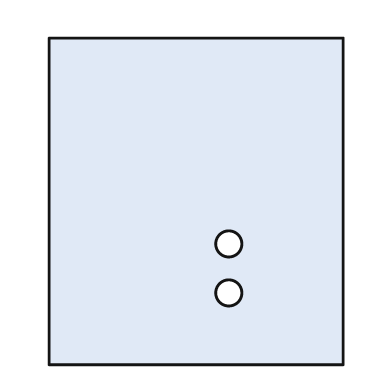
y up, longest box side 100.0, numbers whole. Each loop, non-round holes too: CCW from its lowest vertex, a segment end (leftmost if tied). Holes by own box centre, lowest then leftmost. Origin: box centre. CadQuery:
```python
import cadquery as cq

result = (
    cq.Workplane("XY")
    .moveTo(-45.0, -50.0)
    .lineTo(45.0, -50.0)
    .lineTo(45.0, 50.0)
    .lineTo(-45.0, 50.0)
    .close()
    .moveTo(10.0, -28.0)
    .circle(4.0)
    .moveTo(10.0, -13.0)
    .circle(4.0)
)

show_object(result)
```